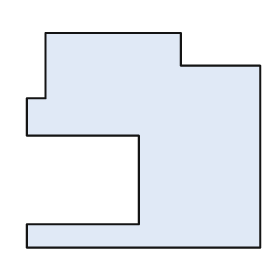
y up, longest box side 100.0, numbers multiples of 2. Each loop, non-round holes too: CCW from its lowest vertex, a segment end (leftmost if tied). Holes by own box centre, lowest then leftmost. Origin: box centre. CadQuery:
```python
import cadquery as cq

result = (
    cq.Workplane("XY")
    .moveTo(-50.0, -46.0)
    .lineTo(50.0, -46.0)
    .lineTo(50.0, 32.0)
    .lineTo(16.0, 32.0)
    .lineTo(16.0, 46.0)
    .lineTo(-42.0, 46.0)
    .lineTo(-42.0, 18.0)
    .lineTo(-50.0, 18.0)
    .lineTo(-50.0, 2.0)
    .lineTo(-2.0, 2.0)
    .lineTo(-2.0, -36.0)
    .lineTo(-50.0, -36.0)
    .close()
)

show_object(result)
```